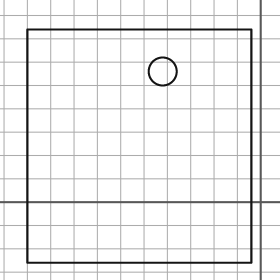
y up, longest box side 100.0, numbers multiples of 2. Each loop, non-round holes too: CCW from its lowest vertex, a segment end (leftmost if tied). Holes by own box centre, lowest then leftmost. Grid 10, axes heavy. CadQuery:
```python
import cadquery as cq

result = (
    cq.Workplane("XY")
    .moveTo(-100.0, -26.0)
    .lineTo(-4.0, -26.0)
    .lineTo(-4.0, 74.0)
    .lineTo(-100.0, 74.0)
    .close()
    .moveTo(-42.0, 56.0)
    .circle(6.0)
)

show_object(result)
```